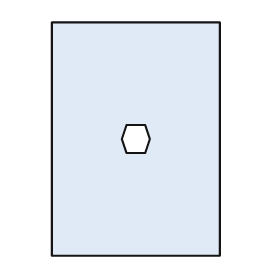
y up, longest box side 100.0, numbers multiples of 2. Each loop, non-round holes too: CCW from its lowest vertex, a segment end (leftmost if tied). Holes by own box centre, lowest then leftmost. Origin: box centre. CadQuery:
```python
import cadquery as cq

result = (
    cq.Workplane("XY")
    .moveTo(-36.0, -50.0)
    .lineTo(36.0, -50.0)
    .lineTo(36.0, 50.0)
    .lineTo(-36.0, 50.0)
    .close()
    .moveTo(-4.0, -6.0)
    .lineTo(4.0, -6.0)
    .lineTo(6.0, 0.0)
    .lineTo(4.0, 6.0)
    .lineTo(-4.0, 6.0)
    .lineTo(-6.0, 0.0)
    .close()
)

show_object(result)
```